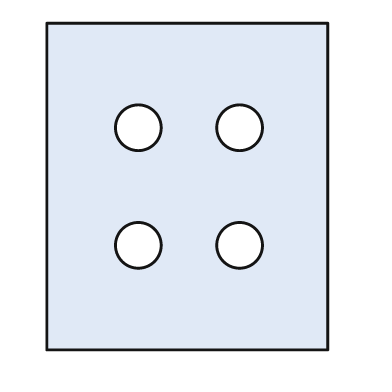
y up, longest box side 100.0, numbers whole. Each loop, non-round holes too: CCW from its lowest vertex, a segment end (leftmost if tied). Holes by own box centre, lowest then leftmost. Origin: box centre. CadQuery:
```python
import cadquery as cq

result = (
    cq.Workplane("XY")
    .moveTo(-43.0, -50.0)
    .lineTo(43.0, -50.0)
    .lineTo(43.0, 50.0)
    .lineTo(-43.0, 50.0)
    .close()
    .moveTo(-15.0, -18.0)
    .circle(7.0)
    .moveTo(16.0, -18.0)
    .circle(7.0)
    .moveTo(-15.0, 18.0)
    .circle(7.0)
    .moveTo(16.0, 18.0)
    .circle(7.0)
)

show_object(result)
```